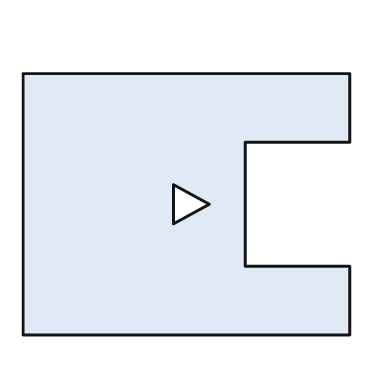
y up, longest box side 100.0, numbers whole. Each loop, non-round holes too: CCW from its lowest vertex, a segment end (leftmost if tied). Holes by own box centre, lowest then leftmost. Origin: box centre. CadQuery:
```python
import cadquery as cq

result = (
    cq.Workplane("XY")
    .moveTo(-50.0, -40.0)
    .lineTo(50.0, -40.0)
    .lineTo(50.0, -19.0)
    .lineTo(18.0, -19.0)
    .lineTo(18.0, 19.0)
    .lineTo(50.0, 19.0)
    .lineTo(50.0, 40.0)
    .lineTo(-50.0, 40.0)
    .close()
    .moveTo(-4.0, -6.0)
    .lineTo(7.0, 0.0)
    .lineTo(-4.0, 6.0)
    .close()
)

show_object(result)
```